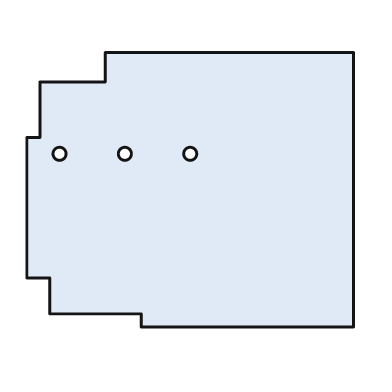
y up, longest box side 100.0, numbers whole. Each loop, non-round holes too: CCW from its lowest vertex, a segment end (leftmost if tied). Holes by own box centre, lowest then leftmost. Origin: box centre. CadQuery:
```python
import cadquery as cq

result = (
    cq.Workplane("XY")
    .moveTo(-15.0, -42.0)
    .lineTo(50.0, -42.0)
    .lineTo(50.0, 42.0)
    .lineTo(-26.0, 42.0)
    .lineTo(-26.0, 33.0)
    .lineTo(-46.0, 33.0)
    .lineTo(-46.0, 16.0)
    .lineTo(-50.0, 16.0)
    .lineTo(-50.0, -27.0)
    .lineTo(-43.0, -27.0)
    .lineTo(-43.0, -38.0)
    .lineTo(-15.0, -38.0)
    .close()
    .moveTo(-40.0, 11.0)
    .circle(2.0)
    .moveTo(-20.0, 11.0)
    .circle(2.0)
    .moveTo(0.0, 11.0)
    .circle(2.0)
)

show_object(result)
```